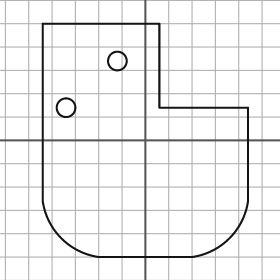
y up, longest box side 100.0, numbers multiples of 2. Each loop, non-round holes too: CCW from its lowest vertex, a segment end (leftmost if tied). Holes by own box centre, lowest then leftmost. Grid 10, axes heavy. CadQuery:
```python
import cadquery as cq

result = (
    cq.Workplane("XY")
    .moveTo(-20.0, -50.0)
    .lineTo(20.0, -50.0)
    .threePointArc((36.0, -42.0), (44.0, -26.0))
    .lineTo(44.0, 14.0)
    .lineTo(6.0, 14.0)
    .lineTo(6.0, 50.0)
    .lineTo(-44.0, 50.0)
    .lineTo(-44.0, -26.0)
    .threePointArc((-36.0, -42.0), (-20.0, -50.0))
    .close()
    .moveTo(-34.0, 14.0)
    .circle(4.0)
    .moveTo(-12.0, 34.0)
    .circle(4.0)
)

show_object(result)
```